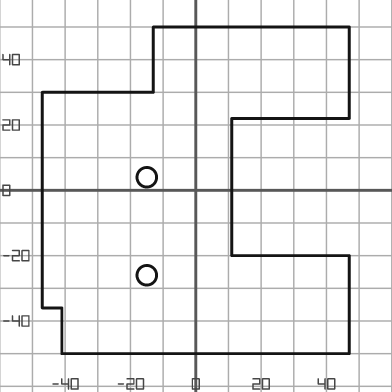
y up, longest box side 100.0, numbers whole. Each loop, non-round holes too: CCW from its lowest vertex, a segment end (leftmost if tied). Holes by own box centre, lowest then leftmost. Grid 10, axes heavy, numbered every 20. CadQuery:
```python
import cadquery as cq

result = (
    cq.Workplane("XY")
    .moveTo(-41.0, -50.0)
    .lineTo(47.0, -50.0)
    .lineTo(47.0, -20.0)
    .lineTo(11.0, -20.0)
    .lineTo(11.0, 22.0)
    .lineTo(47.0, 22.0)
    .lineTo(47.0, 50.0)
    .lineTo(-13.0, 50.0)
    .lineTo(-13.0, 30.0)
    .lineTo(-47.0, 30.0)
    .lineTo(-47.0, -36.0)
    .lineTo(-41.0, -36.0)
    .close()
    .moveTo(-15.0, -26.0)
    .circle(3.0)
    .moveTo(-15.0, 4.0)
    .circle(3.0)
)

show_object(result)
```